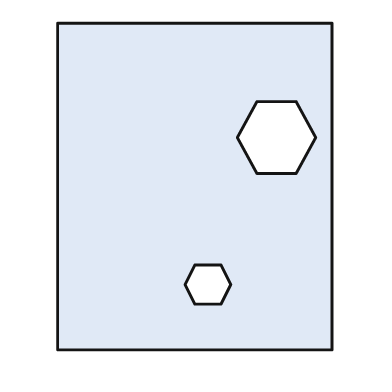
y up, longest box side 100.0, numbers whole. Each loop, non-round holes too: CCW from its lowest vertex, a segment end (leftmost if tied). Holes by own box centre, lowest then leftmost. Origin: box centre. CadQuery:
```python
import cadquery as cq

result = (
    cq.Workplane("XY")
    .moveTo(-42.0, -50.0)
    .lineTo(42.0, -50.0)
    .lineTo(42.0, 50.0)
    .lineTo(-42.0, 50.0)
    .close()
    .moveTo(0.0, -36.0)
    .lineTo(8.0, -36.0)
    .lineTo(11.0, -30.0)
    .lineTo(8.0, -24.0)
    .lineTo(0.0, -24.0)
    .lineTo(-3.0, -30.0)
    .close()
    .moveTo(19.0, 4.0)
    .lineTo(31.0, 4.0)
    .lineTo(37.0, 15.0)
    .lineTo(31.0, 26.0)
    .lineTo(19.0, 26.0)
    .lineTo(13.0, 15.0)
    .close()
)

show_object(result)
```